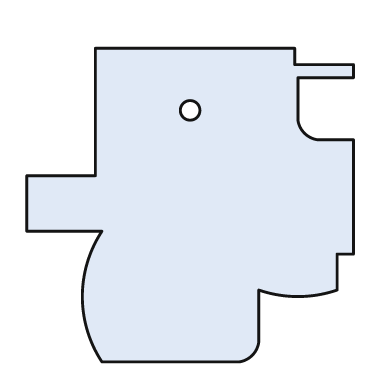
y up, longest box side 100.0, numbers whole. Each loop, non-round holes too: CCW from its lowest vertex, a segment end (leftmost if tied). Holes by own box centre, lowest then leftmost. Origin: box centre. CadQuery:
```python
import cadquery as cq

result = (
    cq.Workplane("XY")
    .moveTo(-27.0, -48.0)
    .lineTo(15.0, -48.0)
    .threePointArc((19.0, -46.0), (21.0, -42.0))
    .lineTo(21.0, -26.0)
    .threePointArc((33.0, -28.0), (45.0, -26.0))
    .lineTo(45.0, -15.0)
    .lineTo(50.0, -15.0)
    .lineTo(50.0, 20.0)
    .lineTo(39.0, 20.0)
    .threePointArc((35.0, 22.0), (33.0, 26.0))
    .lineTo(33.0, 39.0)
    .lineTo(50.0, 39.0)
    .lineTo(50.0, 43.0)
    .lineTo(32.0, 43.0)
    .lineTo(32.0, 48.0)
    .lineTo(-29.0, 48.0)
    .lineTo(-29.0, 9.0)
    .lineTo(-50.0, 9.0)
    .lineTo(-50.0, -8.0)
    .lineTo(-27.0, -8.0)
    .threePointArc((-33.0, -28.0), (-27.0, -48.0))
    .close()
    .moveTo(0.0, 29.0)
    .circle(3.0)
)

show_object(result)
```